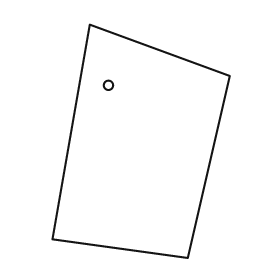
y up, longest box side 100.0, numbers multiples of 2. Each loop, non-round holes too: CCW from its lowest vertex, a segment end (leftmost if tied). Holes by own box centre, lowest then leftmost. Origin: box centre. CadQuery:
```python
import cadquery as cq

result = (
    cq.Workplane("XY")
    .moveTo(20.0, -50.0)
    .lineTo(38.0, 28.0)
    .lineTo(-22.0, 50.0)
    .lineTo(-38.0, -42.0)
    .close()
    .moveTo(-14.0, 24.0)
    .circle(2.0)
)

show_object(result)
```